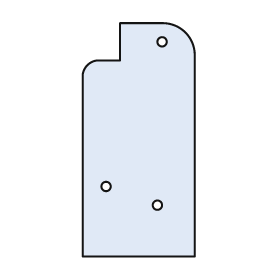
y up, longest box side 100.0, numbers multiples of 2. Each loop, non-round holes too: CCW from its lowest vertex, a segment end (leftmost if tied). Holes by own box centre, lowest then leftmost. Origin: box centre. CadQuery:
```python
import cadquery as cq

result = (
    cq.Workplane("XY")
    .moveTo(-24.0, -50.0)
    .lineTo(24.0, -50.0)
    .lineTo(24.0, 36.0)
    .threePointArc((20.0, 46.0), (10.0, 50.0))
    .lineTo(-8.0, 50.0)
    .lineTo(-8.0, 34.0)
    .lineTo(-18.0, 34.0)
    .threePointArc((-22.0, 32.0), (-24.0, 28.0))
    .close()
    .moveTo(8.0, -28.0)
    .circle(2.0)
    .moveTo(-14.0, -20.0)
    .circle(2.0)
    .moveTo(10.0, 42.0)
    .circle(2.0)
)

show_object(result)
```